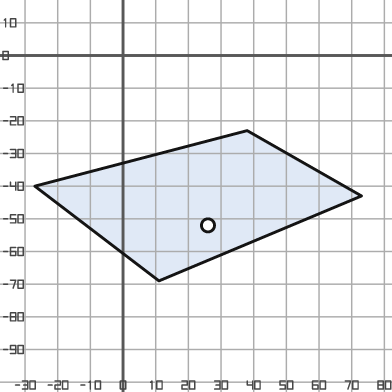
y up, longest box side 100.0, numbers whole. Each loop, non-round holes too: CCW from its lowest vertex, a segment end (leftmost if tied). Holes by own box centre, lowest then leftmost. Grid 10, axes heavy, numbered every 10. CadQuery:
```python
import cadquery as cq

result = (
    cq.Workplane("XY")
    .moveTo(11.0, -69.0)
    .lineTo(73.0, -43.0)
    .lineTo(38.0, -23.0)
    .lineTo(-27.0, -40.0)
    .close()
    .moveTo(26.0, -52.0)
    .circle(2.0)
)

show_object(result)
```